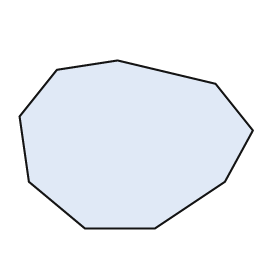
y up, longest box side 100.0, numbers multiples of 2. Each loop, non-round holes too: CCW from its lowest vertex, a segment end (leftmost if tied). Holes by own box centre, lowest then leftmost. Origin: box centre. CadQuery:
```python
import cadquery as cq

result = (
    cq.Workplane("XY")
    .moveTo(-22.0, -36.0)
    .lineTo(8.0, -36.0)
    .lineTo(38.0, -16.0)
    .lineTo(50.0, 6.0)
    .lineTo(34.0, 26.0)
    .lineTo(-8.0, 36.0)
    .lineTo(-34.0, 32.0)
    .lineTo(-50.0, 12.0)
    .lineTo(-46.0, -16.0)
    .close()
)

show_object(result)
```